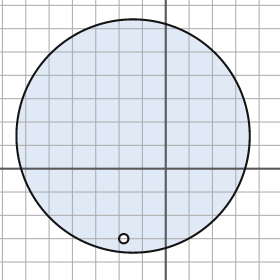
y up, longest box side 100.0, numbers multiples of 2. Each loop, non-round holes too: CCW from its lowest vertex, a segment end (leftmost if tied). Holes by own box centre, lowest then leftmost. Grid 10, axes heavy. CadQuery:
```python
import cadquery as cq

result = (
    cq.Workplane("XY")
    .moveTo(-14.0, 14.0)
    .circle(50.0)
    .moveTo(-18.0, -30.0)
    .circle(2.0)
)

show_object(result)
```